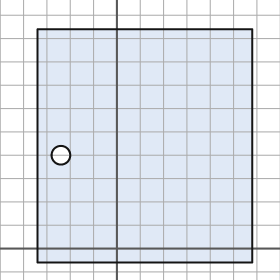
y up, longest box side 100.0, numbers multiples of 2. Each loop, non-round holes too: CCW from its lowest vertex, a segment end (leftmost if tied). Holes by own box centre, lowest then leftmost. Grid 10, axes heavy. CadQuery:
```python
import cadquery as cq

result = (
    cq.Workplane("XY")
    .moveTo(-34.0, -6.0)
    .lineTo(58.0, -6.0)
    .lineTo(58.0, 94.0)
    .lineTo(-34.0, 94.0)
    .close()
    .moveTo(-24.0, 40.0)
    .circle(4.0)
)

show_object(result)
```